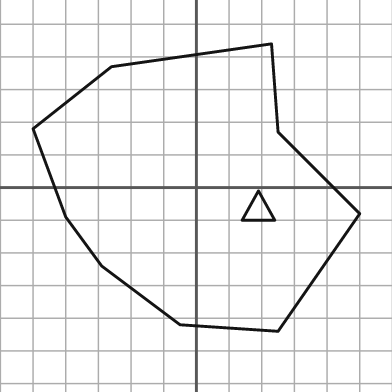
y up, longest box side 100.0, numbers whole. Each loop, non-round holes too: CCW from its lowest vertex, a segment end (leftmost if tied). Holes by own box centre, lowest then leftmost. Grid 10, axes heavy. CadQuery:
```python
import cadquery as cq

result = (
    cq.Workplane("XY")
    .moveTo(25.0, -44.0)
    .lineTo(50.0, -8.0)
    .lineTo(25.0, 17.0)
    .lineTo(23.0, 44.0)
    .lineTo(-26.0, 37.0)
    .lineTo(-50.0, 18.0)
    .lineTo(-40.0, -9.0)
    .lineTo(-29.0, -24.0)
    .lineTo(-5.0, -42.0)
    .close()
    .moveTo(14.0, -10.0)
    .lineTo(24.0, -10.0)
    .lineTo(19.0, -1.0)
    .close()
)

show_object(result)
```